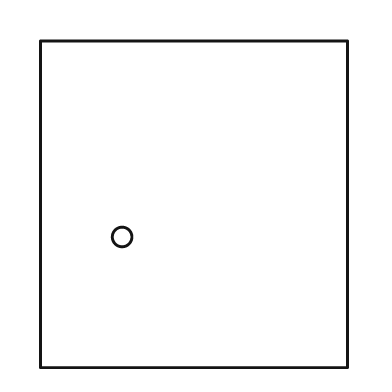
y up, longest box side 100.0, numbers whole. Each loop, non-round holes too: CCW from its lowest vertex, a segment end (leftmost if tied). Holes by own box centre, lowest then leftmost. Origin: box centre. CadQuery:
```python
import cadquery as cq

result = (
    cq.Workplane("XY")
    .moveTo(-47.0, -50.0)
    .lineTo(47.0, -50.0)
    .lineTo(47.0, 50.0)
    .lineTo(-47.0, 50.0)
    .close()
    .moveTo(-22.0, -10.0)
    .circle(3.0)
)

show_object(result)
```